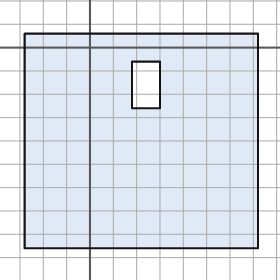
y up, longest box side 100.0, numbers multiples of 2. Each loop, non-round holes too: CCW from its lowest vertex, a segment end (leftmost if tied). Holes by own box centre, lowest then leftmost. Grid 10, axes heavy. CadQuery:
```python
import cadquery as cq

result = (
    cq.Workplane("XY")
    .moveTo(-28.0, -86.0)
    .lineTo(72.0, -86.0)
    .lineTo(72.0, 6.0)
    .lineTo(-28.0, 6.0)
    .close()
    .moveTo(18.0, -26.0)
    .lineTo(30.0, -26.0)
    .lineTo(30.0, -6.0)
    .lineTo(18.0, -6.0)
    .close()
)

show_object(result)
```